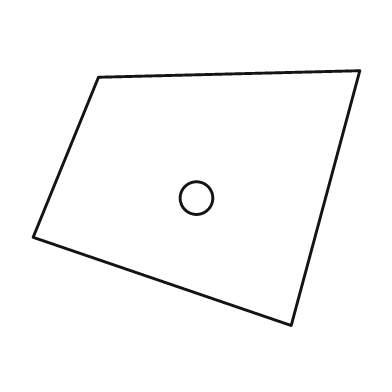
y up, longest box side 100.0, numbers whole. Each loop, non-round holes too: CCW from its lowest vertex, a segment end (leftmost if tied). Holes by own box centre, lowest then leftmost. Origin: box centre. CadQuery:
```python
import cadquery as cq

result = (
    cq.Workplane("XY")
    .moveTo(29.0, -39.0)
    .lineTo(50.0, 39.0)
    .lineTo(-30.0, 37.0)
    .lineTo(-50.0, -12.0)
    .close()
    .moveTo(0.0, 0.0)
    .circle(5.0)
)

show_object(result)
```